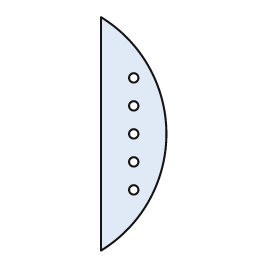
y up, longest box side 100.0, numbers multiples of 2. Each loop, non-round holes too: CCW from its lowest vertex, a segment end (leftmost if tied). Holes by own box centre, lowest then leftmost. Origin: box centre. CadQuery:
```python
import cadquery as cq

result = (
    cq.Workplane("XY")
    .moveTo(-14.0, -50.0)
    .threePointArc((14.0, 0.0), (-14.0, 50.0))
    .close()
    .moveTo(0.0, -24.0)
    .circle(2.0)
    .moveTo(0.0, -12.0)
    .circle(2.0)
    .moveTo(0.0, 0.0)
    .circle(2.0)
    .moveTo(0.0, 12.0)
    .circle(2.0)
    .moveTo(0.0, 24.0)
    .circle(2.0)
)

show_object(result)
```